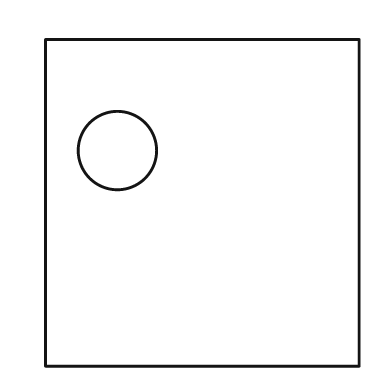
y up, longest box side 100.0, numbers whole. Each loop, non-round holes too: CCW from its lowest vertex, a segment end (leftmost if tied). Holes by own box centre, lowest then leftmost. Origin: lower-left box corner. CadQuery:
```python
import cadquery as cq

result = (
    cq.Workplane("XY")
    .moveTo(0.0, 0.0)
    .lineTo(96.0, 0.0)
    .lineTo(96.0, 100.0)
    .lineTo(0.0, 100.0)
    .close()
    .moveTo(22.0, 66.0)
    .circle(12.0)
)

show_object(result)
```